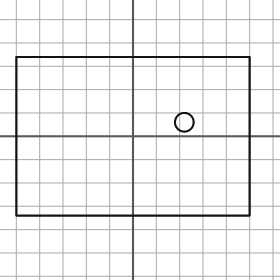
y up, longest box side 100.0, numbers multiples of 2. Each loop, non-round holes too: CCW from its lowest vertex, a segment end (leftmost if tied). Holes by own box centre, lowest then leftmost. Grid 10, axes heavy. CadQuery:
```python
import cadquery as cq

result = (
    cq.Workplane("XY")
    .moveTo(-50.0, -34.0)
    .lineTo(50.0, -34.0)
    .lineTo(50.0, 34.0)
    .lineTo(-50.0, 34.0)
    .close()
    .moveTo(22.0, 6.0)
    .circle(4.0)
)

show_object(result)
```